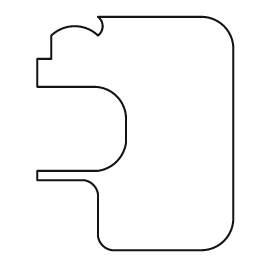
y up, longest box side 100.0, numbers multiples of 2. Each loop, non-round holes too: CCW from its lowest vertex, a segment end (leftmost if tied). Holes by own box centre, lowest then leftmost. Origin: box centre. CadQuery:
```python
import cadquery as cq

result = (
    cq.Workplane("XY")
    .moveTo(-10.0, -50.0)
    .lineTo(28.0, -50.0)
    .threePointArc((38.0, -46.0), (42.0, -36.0))
    .lineTo(42.0, 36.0)
    .threePointArc((38.0, 46.0), (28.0, 50.0))
    .lineTo(-16.0, 50.0)
    .threePointArc((-14.0, 46.0), (-16.0, 42.0))
    .threePointArc((-26.0, 46.0), (-36.0, 42.0))
    .lineTo(-36.0, 32.0)
    .lineTo(-42.0, 32.0)
    .lineTo(-42.0, 20.0)
    .lineTo(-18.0, 20.0)
    .threePointArc((-8.0, 16.0), (-4.0, 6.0))
    .lineTo(-4.0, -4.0)
    .threePointArc((-8.0, -12.0), (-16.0, -16.0))
    .lineTo(-42.0, -16.0)
    .lineTo(-42.0, -20.0)
    .lineTo(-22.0, -20.0)
    .threePointArc((-18.0, -22.0), (-16.0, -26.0))
    .lineTo(-16.0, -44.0)
    .threePointArc((-14.0, -48.0), (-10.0, -50.0))
    .close()
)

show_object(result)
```